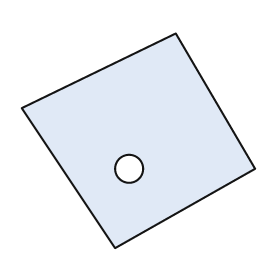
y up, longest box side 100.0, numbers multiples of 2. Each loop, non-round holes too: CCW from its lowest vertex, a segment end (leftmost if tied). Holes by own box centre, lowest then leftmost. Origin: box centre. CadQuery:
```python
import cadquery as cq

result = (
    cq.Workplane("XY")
    .moveTo(-10.0, -46.0)
    .lineTo(50.0, -12.0)
    .lineTo(16.0, 46.0)
    .lineTo(-50.0, 14.0)
    .close()
    .moveTo(-4.0, -12.0)
    .circle(6.0)
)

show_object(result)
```